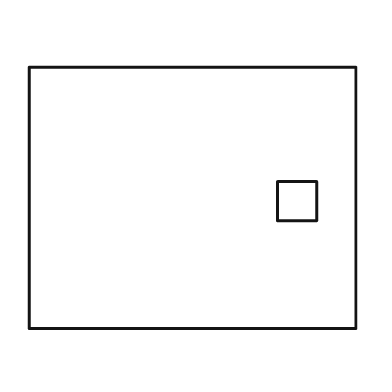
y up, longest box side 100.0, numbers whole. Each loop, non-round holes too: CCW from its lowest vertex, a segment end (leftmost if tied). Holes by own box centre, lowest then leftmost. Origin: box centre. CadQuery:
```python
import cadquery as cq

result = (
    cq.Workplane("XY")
    .moveTo(-50.0, -40.0)
    .lineTo(50.0, -40.0)
    .lineTo(50.0, 40.0)
    .lineTo(-50.0, 40.0)
    .close()
    .moveTo(26.0, -7.0)
    .lineTo(38.0, -7.0)
    .lineTo(38.0, 5.0)
    .lineTo(26.0, 5.0)
    .close()
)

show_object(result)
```